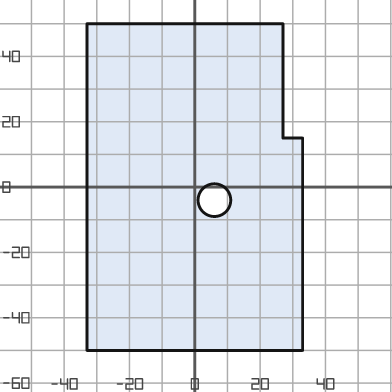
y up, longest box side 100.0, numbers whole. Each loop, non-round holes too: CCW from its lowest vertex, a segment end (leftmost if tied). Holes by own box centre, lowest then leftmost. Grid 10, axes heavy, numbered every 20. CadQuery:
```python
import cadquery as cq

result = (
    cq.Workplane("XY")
    .moveTo(-33.0, -50.0)
    .lineTo(33.0, -50.0)
    .lineTo(33.0, 15.0)
    .lineTo(27.0, 15.0)
    .lineTo(27.0, 50.0)
    .lineTo(-33.0, 50.0)
    .close()
    .moveTo(6.0, -4.0)
    .circle(5.0)
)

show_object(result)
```